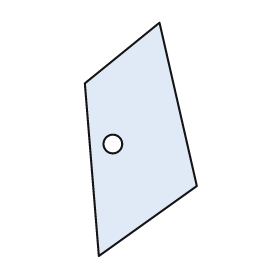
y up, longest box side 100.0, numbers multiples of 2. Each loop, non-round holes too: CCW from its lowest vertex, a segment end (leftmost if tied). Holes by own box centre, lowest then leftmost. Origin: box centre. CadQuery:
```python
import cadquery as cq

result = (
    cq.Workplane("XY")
    .moveTo(-18.0, -50.0)
    .lineTo(24.0, -20.0)
    .lineTo(8.0, 50.0)
    .lineTo(-24.0, 24.0)
    .close()
    .moveTo(-12.0, -2.0)
    .circle(4.0)
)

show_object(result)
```